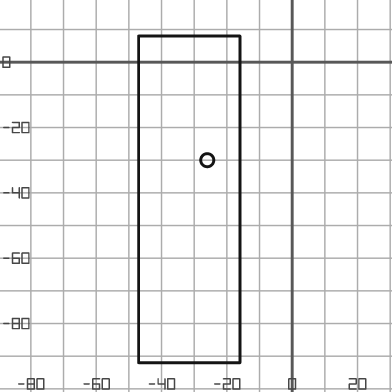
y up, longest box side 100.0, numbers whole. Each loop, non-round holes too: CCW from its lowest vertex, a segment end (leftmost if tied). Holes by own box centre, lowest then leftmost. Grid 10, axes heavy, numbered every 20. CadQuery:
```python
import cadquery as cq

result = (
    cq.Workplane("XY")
    .moveTo(-47.0, -92.0)
    .lineTo(-16.0, -92.0)
    .lineTo(-16.0, 8.0)
    .lineTo(-47.0, 8.0)
    .close()
    .moveTo(-26.0, -30.0)
    .circle(2.0)
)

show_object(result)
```